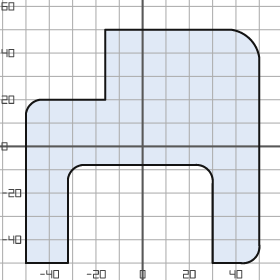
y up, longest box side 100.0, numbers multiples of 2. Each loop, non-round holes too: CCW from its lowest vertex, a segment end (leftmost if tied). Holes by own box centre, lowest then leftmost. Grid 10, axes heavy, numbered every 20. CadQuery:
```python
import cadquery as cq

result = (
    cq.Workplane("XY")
    .moveTo(-50.0, -50.0)
    .lineTo(-32.0, -50.0)
    .lineTo(-32.0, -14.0)
    .threePointArc((-30.0, -10.0), (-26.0, -8.0))
    .lineTo(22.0, -8.0)
    .threePointArc((28.0, -10.0), (30.0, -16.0))
    .lineTo(30.0, -50.0)
    .lineTo(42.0, -50.0)
    .threePointArc((48.0, -48.0), (50.0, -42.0))
    .lineTo(50.0, 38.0)
    .threePointArc((46.0, 46.0), (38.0, 50.0))
    .lineTo(-16.0, 50.0)
    .lineTo(-16.0, 20.0)
    .lineTo(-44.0, 20.0)
    .threePointArc((-48.0, 18.0), (-50.0, 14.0))
    .close()
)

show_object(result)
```